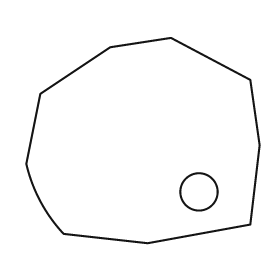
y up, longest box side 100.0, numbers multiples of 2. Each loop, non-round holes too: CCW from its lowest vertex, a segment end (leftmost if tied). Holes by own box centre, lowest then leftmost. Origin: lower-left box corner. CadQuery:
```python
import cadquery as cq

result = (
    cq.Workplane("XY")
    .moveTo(52.0, 0.0)
    .lineTo(96.0, 8.0)
    .lineTo(100.0, 42.0)
    .lineTo(96.0, 70.0)
    .lineTo(62.0, 88.0)
    .lineTo(36.0, 84.0)
    .lineTo(6.0, 64.0)
    .lineTo(0.0, 34.0)
    .threePointArc((6.0, 18.0), (16.0, 4.0))
    .close()
    .moveTo(74.0, 22.0)
    .circle(8.0)
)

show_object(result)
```